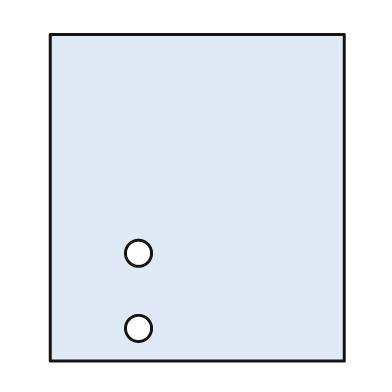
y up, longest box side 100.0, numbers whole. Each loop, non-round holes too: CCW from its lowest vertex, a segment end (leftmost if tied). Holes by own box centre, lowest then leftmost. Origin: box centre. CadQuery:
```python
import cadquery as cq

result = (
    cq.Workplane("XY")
    .moveTo(-45.0, -50.0)
    .lineTo(45.0, -50.0)
    .lineTo(45.0, 50.0)
    .lineTo(-45.0, 50.0)
    .close()
    .moveTo(-18.0, -40.0)
    .circle(4.0)
    .moveTo(-18.0, -17.0)
    .circle(4.0)
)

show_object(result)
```